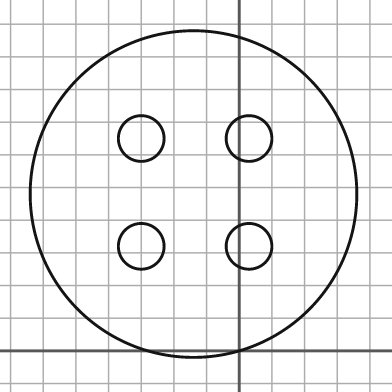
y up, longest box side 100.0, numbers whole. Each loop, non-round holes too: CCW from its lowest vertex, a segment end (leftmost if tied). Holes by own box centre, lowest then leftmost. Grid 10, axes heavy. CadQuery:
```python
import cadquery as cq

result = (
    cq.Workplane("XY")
    .moveTo(-14.0, 48.0)
    .circle(50.0)
    .moveTo(-30.0, 32.0)
    .circle(7.0)
    .moveTo(3.0, 32.0)
    .circle(7.0)
    .moveTo(-30.0, 65.0)
    .circle(7.0)
    .moveTo(3.0, 65.0)
    .circle(7.0)
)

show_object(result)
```